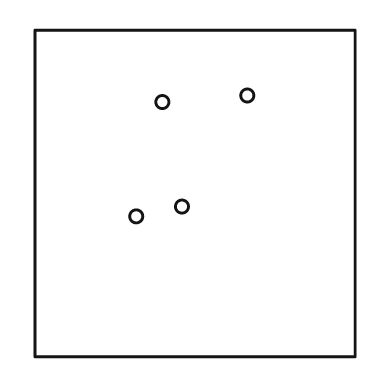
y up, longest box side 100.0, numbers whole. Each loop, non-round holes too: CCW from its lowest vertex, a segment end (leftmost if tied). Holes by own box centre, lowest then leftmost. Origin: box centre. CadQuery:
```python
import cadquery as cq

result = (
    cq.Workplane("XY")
    .moveTo(-49.0, -50.0)
    .lineTo(49.0, -50.0)
    .lineTo(49.0, 50.0)
    .lineTo(-49.0, 50.0)
    .close()
    .moveTo(-18.0, -7.0)
    .circle(2.0)
    .moveTo(-4.0, -4.0)
    .circle(2.0)
    .moveTo(-10.0, 28.0)
    .circle(2.0)
    .moveTo(16.0, 30.0)
    .circle(2.0)
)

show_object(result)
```